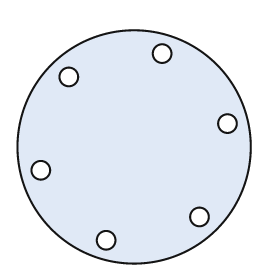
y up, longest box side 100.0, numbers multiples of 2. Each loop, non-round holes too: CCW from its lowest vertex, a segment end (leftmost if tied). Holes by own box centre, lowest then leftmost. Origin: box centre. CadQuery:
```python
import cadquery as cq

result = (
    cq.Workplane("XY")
    .moveTo(0.0, 0.0)
    .circle(50.0)
    .moveTo(-12.0, -40.0)
    .circle(4.0)
    .moveTo(28.0, -30.0)
    .circle(4.0)
    .moveTo(-40.0, -10.0)
    .circle(4.0)
    .moveTo(40.0, 10.0)
    .circle(4.0)
    .moveTo(-28.0, 30.0)
    .circle(4.0)
    .moveTo(12.0, 40.0)
    .circle(4.0)
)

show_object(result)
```